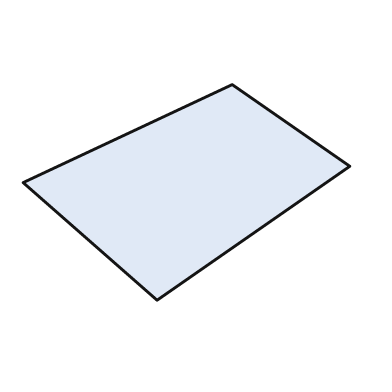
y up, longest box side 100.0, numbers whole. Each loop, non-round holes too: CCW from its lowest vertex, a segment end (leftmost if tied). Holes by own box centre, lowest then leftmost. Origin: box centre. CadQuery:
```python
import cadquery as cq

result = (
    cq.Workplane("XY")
    .moveTo(-9.0, -33.0)
    .lineTo(50.0, 8.0)
    .lineTo(14.0, 33.0)
    .lineTo(-50.0, 3.0)
    .close()
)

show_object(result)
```